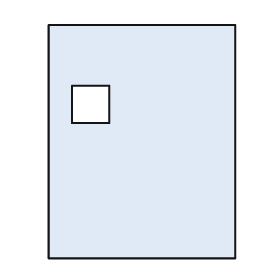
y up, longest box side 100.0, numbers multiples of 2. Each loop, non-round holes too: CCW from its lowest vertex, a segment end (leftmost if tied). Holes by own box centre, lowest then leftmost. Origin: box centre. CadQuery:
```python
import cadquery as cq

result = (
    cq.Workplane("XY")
    .moveTo(-40.0, -50.0)
    .lineTo(40.0, -50.0)
    .lineTo(40.0, 50.0)
    .lineTo(-40.0, 50.0)
    .close()
    .moveTo(-30.0, 8.0)
    .lineTo(-14.0, 8.0)
    .lineTo(-14.0, 24.0)
    .lineTo(-30.0, 24.0)
    .close()
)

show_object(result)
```